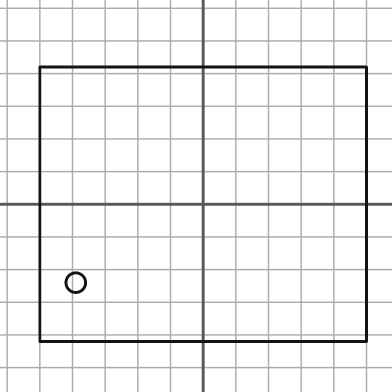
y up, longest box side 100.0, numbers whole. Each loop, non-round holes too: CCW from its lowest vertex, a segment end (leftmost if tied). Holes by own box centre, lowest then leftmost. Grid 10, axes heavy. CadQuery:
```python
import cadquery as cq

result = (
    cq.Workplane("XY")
    .moveTo(-50.0, -42.0)
    .lineTo(50.0, -42.0)
    .lineTo(50.0, 42.0)
    .lineTo(-50.0, 42.0)
    .close()
    .moveTo(-39.0, -24.0)
    .circle(3.0)
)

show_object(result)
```